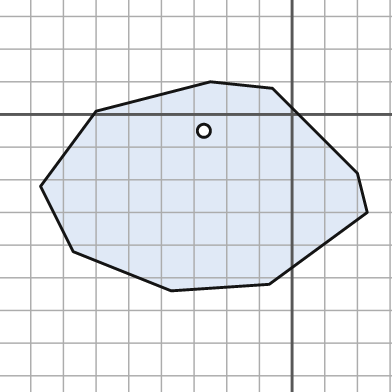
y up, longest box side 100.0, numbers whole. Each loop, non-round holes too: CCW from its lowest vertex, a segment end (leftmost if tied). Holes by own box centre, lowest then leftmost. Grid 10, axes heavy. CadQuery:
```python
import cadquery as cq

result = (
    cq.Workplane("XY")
    .moveTo(-37.0, -54.0)
    .lineTo(-7.0, -52.0)
    .lineTo(23.0, -30.0)
    .lineTo(20.0, -18.0)
    .lineTo(-6.0, 8.0)
    .lineTo(-25.0, 10.0)
    .lineTo(-60.0, 1.0)
    .lineTo(-77.0, -22.0)
    .lineTo(-67.0, -42.0)
    .close()
    .moveTo(-27.0, -5.0)
    .circle(2.0)
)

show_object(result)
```